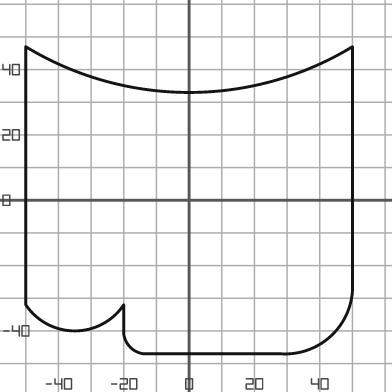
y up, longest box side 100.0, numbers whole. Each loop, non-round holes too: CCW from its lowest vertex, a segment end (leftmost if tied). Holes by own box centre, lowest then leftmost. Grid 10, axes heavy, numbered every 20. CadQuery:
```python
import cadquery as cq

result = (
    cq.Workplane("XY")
    .moveTo(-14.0, -47.0)
    .lineTo(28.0, -47.0)
    .threePointArc((44.0, -41.0), (50.0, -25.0))
    .lineTo(50.0, 47.0)
    .threePointArc((0.0, 33.0), (-50.0, 47.0))
    .lineTo(-50.0, -32.0)
    .threePointArc((-35.0, -40.0), (-20.0, -32.0))
    .lineTo(-20.0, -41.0)
    .threePointArc((-18.0, -45.0), (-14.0, -47.0))
    .close()
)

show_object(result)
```